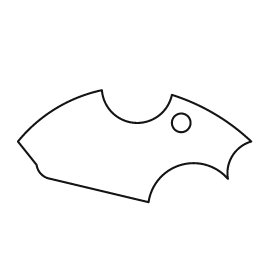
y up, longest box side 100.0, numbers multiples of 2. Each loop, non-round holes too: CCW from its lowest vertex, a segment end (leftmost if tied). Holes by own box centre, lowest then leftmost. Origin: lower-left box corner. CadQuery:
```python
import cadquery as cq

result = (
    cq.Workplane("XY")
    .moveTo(56.0, 0.0)
    .threePointArc((70.0, 16.0), (90.0, 10.0))
    .threePointArc((92.0, 20.0), (100.0, 26.0))
    .threePointArc((84.0, 38.0), (66.0, 46.0))
    .threePointArc((50.0, 34.0), (36.0, 48.0))
    .threePointArc((16.0, 40.0), (0.0, 26.0))
    .lineTo(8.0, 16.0)
    .threePointArc((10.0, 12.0), (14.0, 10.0))
    .close()
    .moveTo(70.0, 34.0)
    .circle(4.0)
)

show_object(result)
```